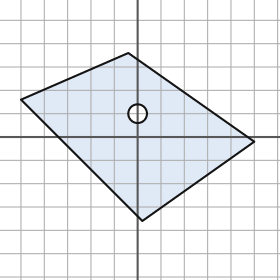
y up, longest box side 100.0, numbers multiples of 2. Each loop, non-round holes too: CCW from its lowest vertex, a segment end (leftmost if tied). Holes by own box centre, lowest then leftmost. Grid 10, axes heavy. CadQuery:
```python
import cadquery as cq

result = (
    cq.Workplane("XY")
    .moveTo(2.0, -36.0)
    .lineTo(50.0, -2.0)
    .lineTo(-4.0, 36.0)
    .lineTo(-50.0, 16.0)
    .close()
    .moveTo(0.0, 10.0)
    .circle(4.0)
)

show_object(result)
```